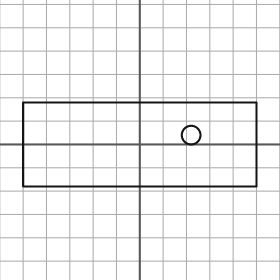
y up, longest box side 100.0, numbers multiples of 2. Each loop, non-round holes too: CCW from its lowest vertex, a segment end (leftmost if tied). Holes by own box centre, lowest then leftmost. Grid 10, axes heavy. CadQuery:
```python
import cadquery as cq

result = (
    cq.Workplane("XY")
    .moveTo(-50.0, -18.0)
    .lineTo(50.0, -18.0)
    .lineTo(50.0, 18.0)
    .lineTo(-50.0, 18.0)
    .close()
    .moveTo(22.0, 4.0)
    .circle(4.0)
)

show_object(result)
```